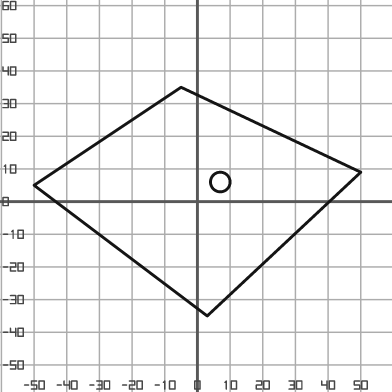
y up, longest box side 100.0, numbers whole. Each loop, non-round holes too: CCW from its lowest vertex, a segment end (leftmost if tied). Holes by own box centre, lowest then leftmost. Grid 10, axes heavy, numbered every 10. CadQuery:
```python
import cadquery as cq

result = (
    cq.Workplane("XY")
    .moveTo(3.0, -35.0)
    .lineTo(50.0, 9.0)
    .lineTo(-5.0, 35.0)
    .lineTo(-50.0, 5.0)
    .close()
    .moveTo(7.0, 6.0)
    .circle(3.0)
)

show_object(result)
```